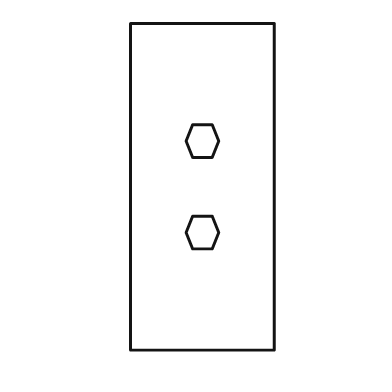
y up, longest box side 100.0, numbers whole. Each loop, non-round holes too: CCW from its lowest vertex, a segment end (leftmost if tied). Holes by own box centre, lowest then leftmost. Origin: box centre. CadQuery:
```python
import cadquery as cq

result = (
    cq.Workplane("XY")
    .moveTo(-22.0, -50.0)
    .lineTo(22.0, -50.0)
    .lineTo(22.0, 50.0)
    .lineTo(-22.0, 50.0)
    .close()
    .moveTo(-3.0, -19.0)
    .lineTo(3.0, -19.0)
    .lineTo(5.0, -14.0)
    .lineTo(3.0, -9.0)
    .lineTo(-3.0, -9.0)
    .lineTo(-5.0, -14.0)
    .close()
    .moveTo(-3.0, 9.0)
    .lineTo(3.0, 9.0)
    .lineTo(5.0, 14.0)
    .lineTo(3.0, 19.0)
    .lineTo(-3.0, 19.0)
    .lineTo(-5.0, 14.0)
    .close()
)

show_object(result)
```